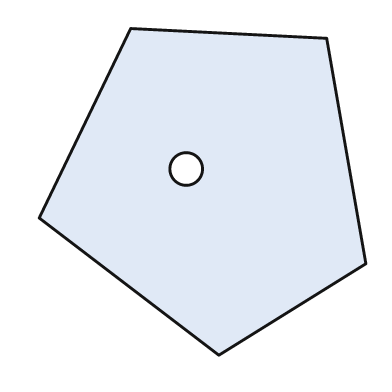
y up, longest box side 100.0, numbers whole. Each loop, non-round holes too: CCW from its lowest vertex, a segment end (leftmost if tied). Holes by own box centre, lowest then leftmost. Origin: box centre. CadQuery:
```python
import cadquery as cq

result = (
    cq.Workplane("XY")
    .moveTo(5.0, -50.0)
    .lineTo(50.0, -22.0)
    .lineTo(38.0, 47.0)
    .lineTo(-22.0, 50.0)
    .lineTo(-50.0, -8.0)
    .close()
    .moveTo(-5.0, 7.0)
    .circle(5.0)
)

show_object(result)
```